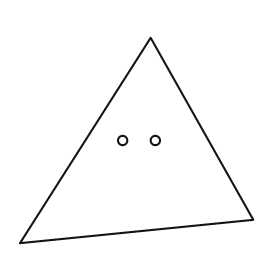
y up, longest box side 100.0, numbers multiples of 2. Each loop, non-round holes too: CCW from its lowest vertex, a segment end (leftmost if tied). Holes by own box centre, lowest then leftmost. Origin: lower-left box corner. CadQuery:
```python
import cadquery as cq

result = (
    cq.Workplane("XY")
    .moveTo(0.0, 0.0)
    .lineTo(100.0, 10.0)
    .lineTo(56.0, 88.0)
    .close()
    .moveTo(44.0, 44.0)
    .circle(2.0)
    .moveTo(58.0, 44.0)
    .circle(2.0)
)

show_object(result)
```